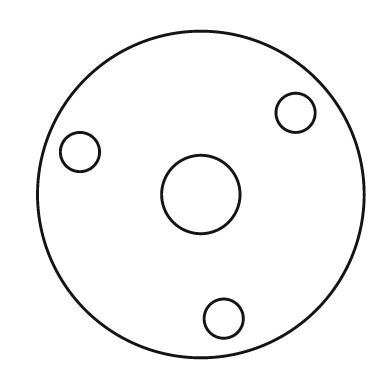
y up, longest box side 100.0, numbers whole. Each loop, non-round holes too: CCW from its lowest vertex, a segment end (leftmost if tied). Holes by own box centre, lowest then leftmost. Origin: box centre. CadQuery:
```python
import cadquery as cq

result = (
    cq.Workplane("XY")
    .moveTo(0.0, 0.0)
    .circle(50.0)
    .moveTo(7.0, -38.0)
    .circle(6.0)
    .moveTo(0.0, 0.0)
    .circle(12.0)
    .moveTo(-37.0, 13.0)
    .circle(6.0)
    .moveTo(29.0, 25.0)
    .circle(6.0)
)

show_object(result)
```